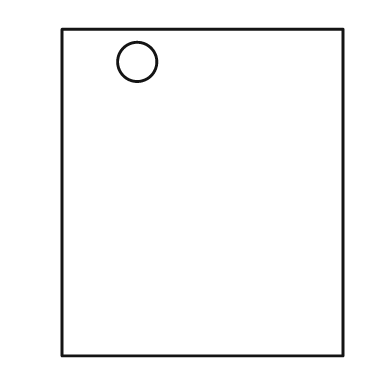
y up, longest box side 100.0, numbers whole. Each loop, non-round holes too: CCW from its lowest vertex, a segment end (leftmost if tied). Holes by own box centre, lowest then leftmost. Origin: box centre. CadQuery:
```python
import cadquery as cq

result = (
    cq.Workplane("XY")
    .moveTo(-43.0, -50.0)
    .lineTo(43.0, -50.0)
    .lineTo(43.0, 50.0)
    .lineTo(-43.0, 50.0)
    .close()
    .moveTo(-20.0, 40.0)
    .circle(6.0)
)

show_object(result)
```